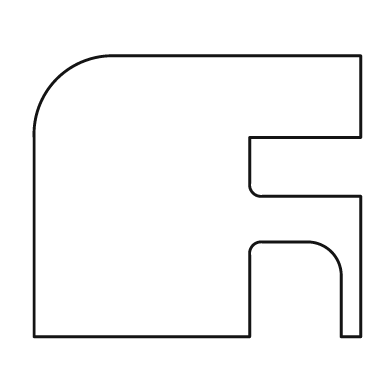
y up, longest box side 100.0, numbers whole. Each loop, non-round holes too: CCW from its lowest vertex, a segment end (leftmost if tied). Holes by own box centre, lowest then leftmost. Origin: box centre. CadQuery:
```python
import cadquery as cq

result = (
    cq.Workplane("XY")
    .moveTo(-50.0, -43.0)
    .lineTo(16.0, -43.0)
    .lineTo(16.0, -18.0)
    .threePointArc((17.0, -15.0), (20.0, -14.0))
    .lineTo(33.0, -14.0)
    .threePointArc((41.0, -17.0), (44.0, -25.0))
    .lineTo(44.0, -43.0)
    .lineTo(50.0, -43.0)
    .lineTo(50.0, 0.0)
    .lineTo(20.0, 0.0)
    .threePointArc((17.0, 1.0), (16.0, 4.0))
    .lineTo(16.0, 18.0)
    .lineTo(50.0, 18.0)
    .lineTo(50.0, 43.0)
    .lineTo(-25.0, 43.0)
    .threePointArc((-43.0, 36.0), (-50.0, 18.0))
    .close()
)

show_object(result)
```